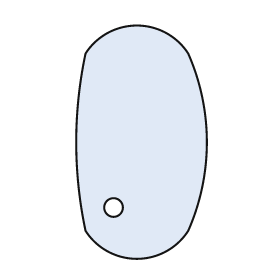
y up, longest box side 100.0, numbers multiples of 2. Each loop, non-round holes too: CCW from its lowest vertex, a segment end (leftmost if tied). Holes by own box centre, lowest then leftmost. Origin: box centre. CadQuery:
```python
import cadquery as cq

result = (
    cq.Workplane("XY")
    .moveTo(-24.0, -38.0)
    .threePointArc((-2.0, -50.0), (20.0, -38.0))
    .threePointArc((28.0, 0.0), (20.0, 38.0))
    .threePointArc((-2.0, 50.0), (-24.0, 38.0))
    .threePointArc((-28.0, 0.0), (-24.0, -38.0))
    .close()
    .moveTo(-12.0, -28.0)
    .circle(4.0)
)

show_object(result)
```